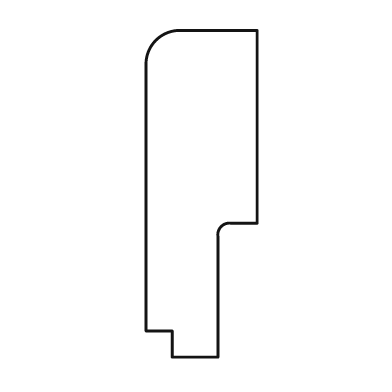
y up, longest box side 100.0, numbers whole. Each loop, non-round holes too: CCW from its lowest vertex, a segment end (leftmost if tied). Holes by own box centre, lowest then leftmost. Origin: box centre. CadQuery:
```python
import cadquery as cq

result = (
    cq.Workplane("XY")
    .moveTo(-9.0, -50.0)
    .lineTo(5.0, -50.0)
    .lineTo(5.0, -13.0)
    .threePointArc((6.0, -10.0), (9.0, -9.0))
    .lineTo(17.0, -9.0)
    .lineTo(17.0, 50.0)
    .lineTo(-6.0, 50.0)
    .threePointArc((-14.0, 47.0), (-17.0, 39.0))
    .lineTo(-17.0, -42.0)
    .lineTo(-9.0, -42.0)
    .close()
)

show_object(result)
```